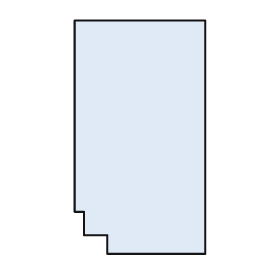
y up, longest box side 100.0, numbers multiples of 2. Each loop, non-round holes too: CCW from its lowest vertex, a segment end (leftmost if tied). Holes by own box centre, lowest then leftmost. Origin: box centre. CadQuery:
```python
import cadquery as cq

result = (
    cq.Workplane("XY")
    .moveTo(-14.0, -50.0)
    .lineTo(28.0, -50.0)
    .lineTo(28.0, 50.0)
    .lineTo(-28.0, 50.0)
    .lineTo(-28.0, -32.0)
    .lineTo(-24.0, -32.0)
    .lineTo(-24.0, -42.0)
    .lineTo(-14.0, -42.0)
    .close()
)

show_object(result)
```